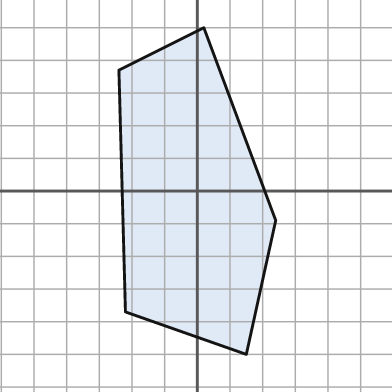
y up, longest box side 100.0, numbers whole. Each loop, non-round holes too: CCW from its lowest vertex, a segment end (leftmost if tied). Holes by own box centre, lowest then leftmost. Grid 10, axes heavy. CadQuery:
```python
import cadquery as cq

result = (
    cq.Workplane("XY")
    .moveTo(15.0, -50.0)
    .lineTo(24.0, -9.0)
    .lineTo(2.0, 50.0)
    .lineTo(-24.0, 37.0)
    .lineTo(-22.0, -37.0)
    .close()
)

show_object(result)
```